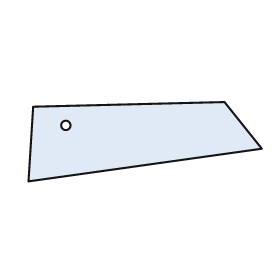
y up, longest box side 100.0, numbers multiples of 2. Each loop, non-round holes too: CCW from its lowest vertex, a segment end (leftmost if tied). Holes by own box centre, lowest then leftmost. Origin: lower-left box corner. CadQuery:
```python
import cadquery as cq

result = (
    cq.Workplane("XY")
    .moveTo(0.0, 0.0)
    .lineTo(100.0, 14.0)
    .lineTo(84.0, 34.0)
    .lineTo(2.0, 32.0)
    .close()
    .moveTo(16.0, 24.0)
    .circle(2.0)
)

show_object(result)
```